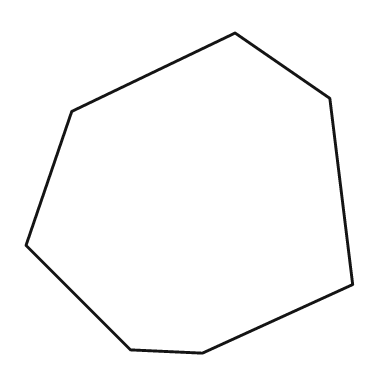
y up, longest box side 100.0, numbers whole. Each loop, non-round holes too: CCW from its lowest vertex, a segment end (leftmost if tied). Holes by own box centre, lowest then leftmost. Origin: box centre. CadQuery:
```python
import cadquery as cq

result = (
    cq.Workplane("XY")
    .moveTo(4.0, -49.0)
    .lineTo(50.0, -28.0)
    .lineTo(43.0, 29.0)
    .lineTo(14.0, 49.0)
    .lineTo(-36.0, 25.0)
    .lineTo(-50.0, -16.0)
    .lineTo(-18.0, -48.0)
    .close()
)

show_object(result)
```